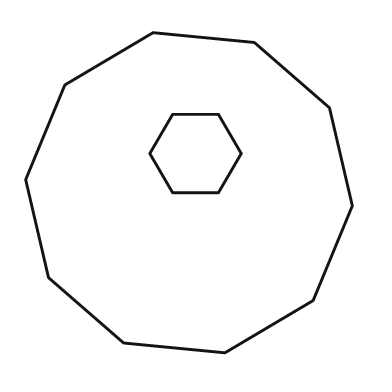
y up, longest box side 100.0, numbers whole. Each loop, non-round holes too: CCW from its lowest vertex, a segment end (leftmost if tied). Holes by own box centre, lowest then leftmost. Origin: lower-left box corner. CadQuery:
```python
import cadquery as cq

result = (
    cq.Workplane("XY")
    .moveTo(61.0, 0.0)
    .lineTo(88.0, 16.0)
    .lineTo(100.0, 45.0)
    .lineTo(93.0, 75.0)
    .lineTo(70.0, 95.0)
    .lineTo(39.0, 98.0)
    .lineTo(12.0, 82.0)
    .lineTo(0.0, 53.0)
    .lineTo(7.0, 23.0)
    .lineTo(30.0, 3.0)
    .close()
    .moveTo(45.0, 49.0)
    .lineTo(59.0, 49.0)
    .lineTo(66.0, 61.0)
    .lineTo(59.0, 73.0)
    .lineTo(45.0, 73.0)
    .lineTo(38.0, 61.0)
    .close()
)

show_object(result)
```